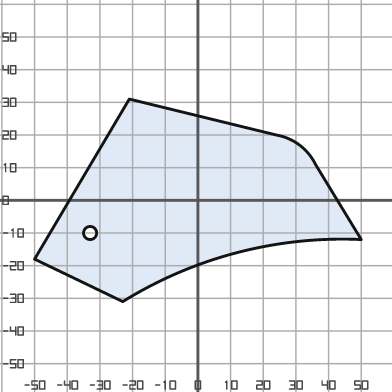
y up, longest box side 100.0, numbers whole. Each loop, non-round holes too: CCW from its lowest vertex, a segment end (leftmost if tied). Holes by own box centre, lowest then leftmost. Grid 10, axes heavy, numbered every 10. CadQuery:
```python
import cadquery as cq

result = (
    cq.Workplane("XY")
    .moveTo(-23.0, -31.0)
    .threePointArc((12.0, -16.0), (50.0, -12.0))
    .lineTo(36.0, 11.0)
    .threePointArc((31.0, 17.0), (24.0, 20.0))
    .lineTo(-21.0, 31.0)
    .lineTo(-50.0, -18.0)
    .close()
    .moveTo(-33.0, -10.0)
    .circle(2.0)
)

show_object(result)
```